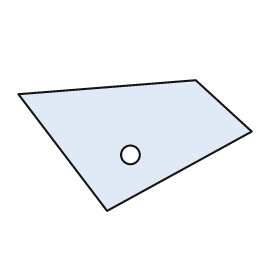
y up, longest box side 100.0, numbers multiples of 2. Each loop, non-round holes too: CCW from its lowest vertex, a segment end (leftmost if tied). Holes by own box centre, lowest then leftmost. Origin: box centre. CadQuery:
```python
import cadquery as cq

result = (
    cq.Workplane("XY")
    .moveTo(-12.0, -28.0)
    .lineTo(50.0, 6.0)
    .lineTo(26.0, 28.0)
    .lineTo(-50.0, 22.0)
    .close()
    .moveTo(-2.0, -4.0)
    .circle(4.0)
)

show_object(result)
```